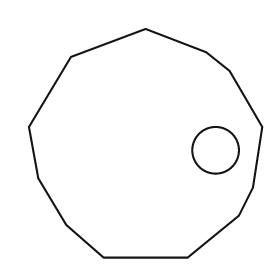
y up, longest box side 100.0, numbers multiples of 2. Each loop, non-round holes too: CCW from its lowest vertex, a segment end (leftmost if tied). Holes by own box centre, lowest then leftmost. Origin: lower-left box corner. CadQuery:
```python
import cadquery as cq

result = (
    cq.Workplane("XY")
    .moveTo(32.0, 0.0)
    .lineTo(68.0, 0.0)
    .lineTo(90.0, 18.0)
    .lineTo(96.0, 30.0)
    .lineTo(100.0, 56.0)
    .lineTo(86.0, 80.0)
    .lineTo(76.0, 88.0)
    .lineTo(50.0, 98.0)
    .lineTo(18.0, 86.0)
    .lineTo(0.0, 56.0)
    .lineTo(4.0, 34.0)
    .lineTo(16.0, 14.0)
    .close()
    .moveTo(80.0, 46.0)
    .circle(10.0)
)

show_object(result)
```